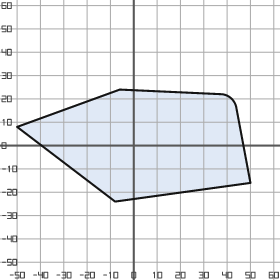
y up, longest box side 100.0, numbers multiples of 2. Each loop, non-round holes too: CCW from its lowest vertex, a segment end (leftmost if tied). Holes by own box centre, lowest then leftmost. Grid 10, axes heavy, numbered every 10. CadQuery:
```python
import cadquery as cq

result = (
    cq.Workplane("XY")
    .moveTo(-8.0, -24.0)
    .lineTo(50.0, -16.0)
    .lineTo(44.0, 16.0)
    .threePointArc((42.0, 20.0), (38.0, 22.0))
    .lineTo(-6.0, 24.0)
    .lineTo(-50.0, 8.0)
    .close()
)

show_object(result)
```